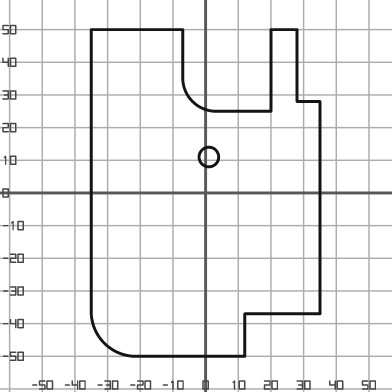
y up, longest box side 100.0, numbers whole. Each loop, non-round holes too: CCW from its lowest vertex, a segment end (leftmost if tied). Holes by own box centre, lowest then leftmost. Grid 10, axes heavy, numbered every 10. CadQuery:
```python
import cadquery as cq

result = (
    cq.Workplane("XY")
    .moveTo(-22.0, -50.0)
    .lineTo(12.0, -50.0)
    .lineTo(12.0, -37.0)
    .lineTo(35.0, -37.0)
    .lineTo(35.0, 28.0)
    .lineTo(28.0, 28.0)
    .lineTo(28.0, 50.0)
    .lineTo(20.0, 50.0)
    .lineTo(20.0, 25.0)
    .lineTo(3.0, 25.0)
    .threePointArc((-4.0, 28.0), (-7.0, 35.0))
    .lineTo(-7.0, 50.0)
    .lineTo(-35.0, 50.0)
    .lineTo(-35.0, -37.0)
    .threePointArc((-31.0, -46.0), (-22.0, -50.0))
    .close()
    .moveTo(1.0, 11.0)
    .circle(3.0)
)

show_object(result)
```